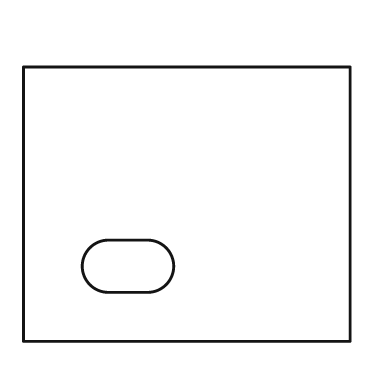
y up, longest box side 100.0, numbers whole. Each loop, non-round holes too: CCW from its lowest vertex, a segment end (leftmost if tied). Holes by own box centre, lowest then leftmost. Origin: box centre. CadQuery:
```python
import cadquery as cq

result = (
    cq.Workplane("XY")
    .moveTo(-50.0, -42.0)
    .lineTo(50.0, -42.0)
    .lineTo(50.0, 42.0)
    .lineTo(-50.0, 42.0)
    .close()
    .moveTo(-24.0, -27.0)
    .lineTo(-12.0, -27.0)
    .threePointArc((-4.0, -19.0), (-12.0, -11.0))
    .lineTo(-24.0, -11.0)
    .threePointArc((-32.0, -19.0), (-24.0, -27.0))
    .close()
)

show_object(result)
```